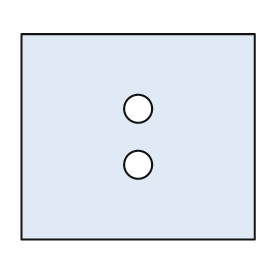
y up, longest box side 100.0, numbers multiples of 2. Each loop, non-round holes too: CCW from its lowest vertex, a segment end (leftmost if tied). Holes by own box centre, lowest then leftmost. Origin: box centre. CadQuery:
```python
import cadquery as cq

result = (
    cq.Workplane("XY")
    .moveTo(-50.0, -44.0)
    .lineTo(50.0, -44.0)
    .lineTo(50.0, 44.0)
    .lineTo(-50.0, 44.0)
    .close()
    .moveTo(0.0, -12.0)
    .circle(6.0)
    .moveTo(0.0, 12.0)
    .circle(6.0)
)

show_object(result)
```